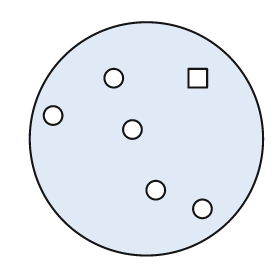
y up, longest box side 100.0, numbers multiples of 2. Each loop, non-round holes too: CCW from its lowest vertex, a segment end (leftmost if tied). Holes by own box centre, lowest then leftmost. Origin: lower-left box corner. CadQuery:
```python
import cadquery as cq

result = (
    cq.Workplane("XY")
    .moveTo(50.0, 50.0)
    .circle(50.0)
    .moveTo(74.0, 20.0)
    .circle(4.0)
    .moveTo(54.0, 28.0)
    .circle(4.0)
    .moveTo(44.0, 54.0)
    .circle(4.0)
    .moveTo(10.0, 60.0)
    .circle(4.0)
    .moveTo(36.0, 76.0)
    .circle(4.0)
    .moveTo(68.0, 72.0)
    .lineTo(76.0, 72.0)
    .lineTo(76.0, 80.0)
    .lineTo(68.0, 80.0)
    .close()
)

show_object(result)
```